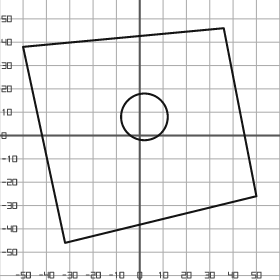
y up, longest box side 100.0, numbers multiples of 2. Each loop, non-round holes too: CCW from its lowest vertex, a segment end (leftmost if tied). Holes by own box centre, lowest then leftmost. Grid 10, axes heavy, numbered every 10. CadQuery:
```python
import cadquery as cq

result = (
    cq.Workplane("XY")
    .moveTo(-32.0, -46.0)
    .lineTo(50.0, -26.0)
    .lineTo(36.0, 46.0)
    .lineTo(-50.0, 38.0)
    .close()
    .moveTo(2.0, 8.0)
    .circle(10.0)
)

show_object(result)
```